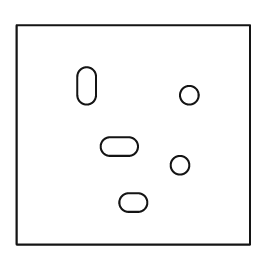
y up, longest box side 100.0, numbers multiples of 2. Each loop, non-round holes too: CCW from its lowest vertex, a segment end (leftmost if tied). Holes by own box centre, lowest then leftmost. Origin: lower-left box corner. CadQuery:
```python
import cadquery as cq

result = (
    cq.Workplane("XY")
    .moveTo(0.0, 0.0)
    .lineTo(100.0, 0.0)
    .lineTo(100.0, 94.0)
    .lineTo(0.0, 94.0)
    .close()
    .moveTo(48.0, 14.0)
    .lineTo(52.0, 14.0)
    .threePointArc((56.0, 18.0), (52.0, 22.0))
    .lineTo(48.0, 22.0)
    .threePointArc((44.0, 18.0), (48.0, 14.0))
    .close()
    .moveTo(70.0, 34.0)
    .circle(4.0)
    .moveTo(40.0, 38.0)
    .lineTo(48.0, 38.0)
    .threePointArc((52.0, 42.0), (48.0, 46.0))
    .lineTo(40.0, 46.0)
    .threePointArc((36.0, 42.0), (40.0, 38.0))
    .close()
    .moveTo(74.0, 64.0)
    .circle(4.0)
    .moveTo(26.0, 64.0)
    .threePointArc((30.0, 60.0), (34.0, 64.0))
    .lineTo(34.0, 72.0)
    .threePointArc((30.0, 76.0), (26.0, 72.0))
    .close()
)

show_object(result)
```